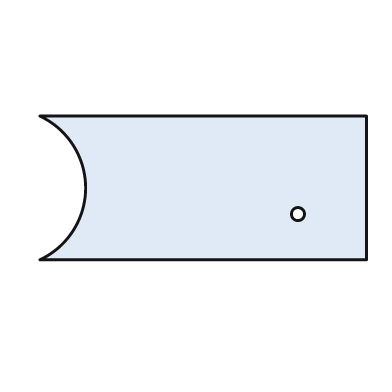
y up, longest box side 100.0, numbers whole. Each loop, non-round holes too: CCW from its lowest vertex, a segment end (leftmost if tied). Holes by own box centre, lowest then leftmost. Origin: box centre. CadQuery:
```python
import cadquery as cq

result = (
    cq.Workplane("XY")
    .moveTo(-50.0, -22.0)
    .lineTo(50.0, -22.0)
    .lineTo(50.0, 22.0)
    .lineTo(-50.0, 22.0)
    .threePointArc((-36.0, 0.0), (-50.0, -22.0))
    .close()
    .moveTo(29.0, -8.0)
    .circle(2.0)
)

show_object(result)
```